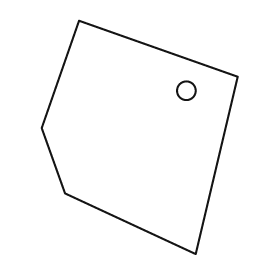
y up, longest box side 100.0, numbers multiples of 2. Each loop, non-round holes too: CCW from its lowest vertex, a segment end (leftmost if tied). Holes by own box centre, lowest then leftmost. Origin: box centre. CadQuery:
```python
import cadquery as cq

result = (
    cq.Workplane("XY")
    .moveTo(24.0, -50.0)
    .lineTo(42.0, 26.0)
    .lineTo(-26.0, 50.0)
    .lineTo(-42.0, 4.0)
    .lineTo(-32.0, -24.0)
    .close()
    .moveTo(20.0, 20.0)
    .circle(4.0)
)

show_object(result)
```